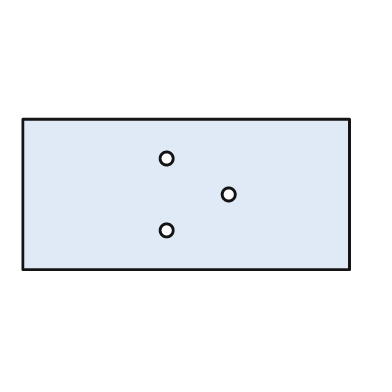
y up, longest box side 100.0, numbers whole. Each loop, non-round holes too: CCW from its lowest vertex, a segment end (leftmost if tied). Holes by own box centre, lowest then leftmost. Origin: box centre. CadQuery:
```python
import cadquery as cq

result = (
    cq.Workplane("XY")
    .moveTo(-50.0, -23.0)
    .lineTo(50.0, -23.0)
    .lineTo(50.0, 23.0)
    .lineTo(-50.0, 23.0)
    .close()
    .moveTo(-6.0, -11.0)
    .circle(2.0)
    .moveTo(13.0, 0.0)
    .circle(2.0)
    .moveTo(-6.0, 11.0)
    .circle(2.0)
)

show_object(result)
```